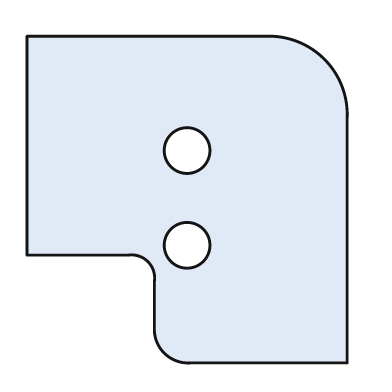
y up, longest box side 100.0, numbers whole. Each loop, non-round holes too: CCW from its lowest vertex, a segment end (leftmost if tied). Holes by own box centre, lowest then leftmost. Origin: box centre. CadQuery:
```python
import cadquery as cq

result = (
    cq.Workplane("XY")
    .moveTo(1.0, -50.0)
    .lineTo(49.0, -50.0)
    .lineTo(49.0, 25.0)
    .threePointArc((42.0, 43.0), (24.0, 50.0))
    .lineTo(-49.0, 50.0)
    .lineTo(-49.0, -17.0)
    .lineTo(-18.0, -17.0)
    .threePointArc((-12.0, -19.0), (-10.0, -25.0))
    .lineTo(-10.0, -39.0)
    .threePointArc((-7.0, -47.0), (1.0, -50.0))
    .close()
    .moveTo(0.0, -14.0)
    .circle(7.0)
    .moveTo(0.0, 15.0)
    .circle(7.0)
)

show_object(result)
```